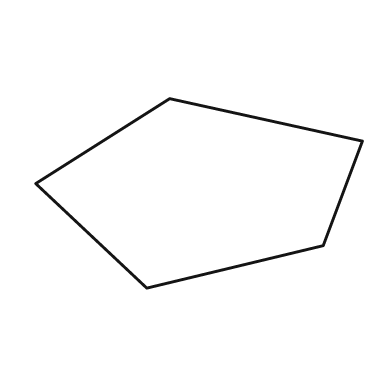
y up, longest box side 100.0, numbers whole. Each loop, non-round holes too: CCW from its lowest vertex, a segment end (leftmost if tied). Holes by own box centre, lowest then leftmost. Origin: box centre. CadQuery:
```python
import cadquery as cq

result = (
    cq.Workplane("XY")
    .moveTo(-16.0, -29.0)
    .lineTo(38.0, -16.0)
    .lineTo(50.0, 16.0)
    .lineTo(-9.0, 29.0)
    .lineTo(-50.0, 3.0)
    .close()
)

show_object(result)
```